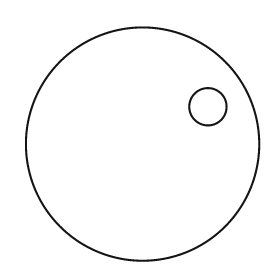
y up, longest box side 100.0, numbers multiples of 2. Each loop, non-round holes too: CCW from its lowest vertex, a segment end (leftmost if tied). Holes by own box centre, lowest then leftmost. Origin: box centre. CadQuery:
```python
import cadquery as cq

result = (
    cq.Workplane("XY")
    .moveTo(0.0, 0.0)
    .circle(50.0)
    .moveTo(28.0, 16.0)
    .circle(8.0)
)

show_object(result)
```